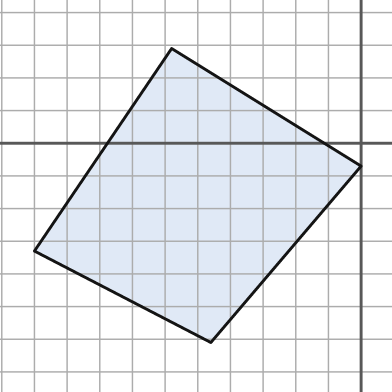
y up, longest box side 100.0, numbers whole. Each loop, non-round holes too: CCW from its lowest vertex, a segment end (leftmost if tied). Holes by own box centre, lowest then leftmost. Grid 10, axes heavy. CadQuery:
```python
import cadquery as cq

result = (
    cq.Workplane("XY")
    .moveTo(-46.0, -61.0)
    .lineTo(0.0, -7.0)
    .lineTo(-58.0, 29.0)
    .lineTo(-100.0, -33.0)
    .close()
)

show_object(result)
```